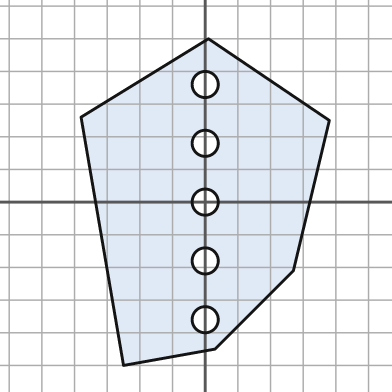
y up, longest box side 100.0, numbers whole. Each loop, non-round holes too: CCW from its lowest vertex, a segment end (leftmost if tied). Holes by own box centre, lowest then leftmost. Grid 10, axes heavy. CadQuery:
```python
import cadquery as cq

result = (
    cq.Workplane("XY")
    .moveTo(-25.0, -50.0)
    .lineTo(3.0, -45.0)
    .lineTo(27.0, -21.0)
    .lineTo(38.0, 25.0)
    .lineTo(1.0, 50.0)
    .lineTo(-38.0, 26.0)
    .close()
    .moveTo(0.0, -36.0)
    .circle(4.0)
    .moveTo(0.0, -18.0)
    .circle(4.0)
    .moveTo(0.0, 0.0)
    .circle(4.0)
    .moveTo(0.0, 18.0)
    .circle(4.0)
    .moveTo(0.0, 36.0)
    .circle(4.0)
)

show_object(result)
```